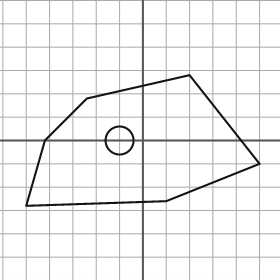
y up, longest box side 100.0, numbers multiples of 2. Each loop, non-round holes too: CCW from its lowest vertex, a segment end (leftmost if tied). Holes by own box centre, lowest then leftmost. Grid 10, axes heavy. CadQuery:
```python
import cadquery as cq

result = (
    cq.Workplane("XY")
    .moveTo(-50.0, -28.0)
    .lineTo(10.0, -26.0)
    .lineTo(50.0, -10.0)
    .lineTo(20.0, 28.0)
    .lineTo(-24.0, 18.0)
    .lineTo(-42.0, 0.0)
    .close()
    .moveTo(-10.0, 0.0)
    .circle(6.0)
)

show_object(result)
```